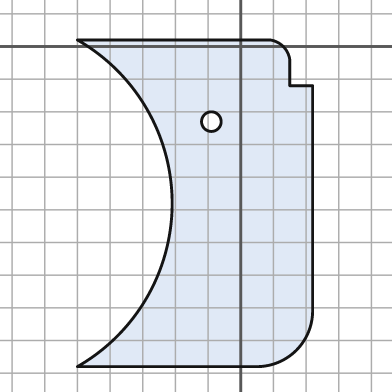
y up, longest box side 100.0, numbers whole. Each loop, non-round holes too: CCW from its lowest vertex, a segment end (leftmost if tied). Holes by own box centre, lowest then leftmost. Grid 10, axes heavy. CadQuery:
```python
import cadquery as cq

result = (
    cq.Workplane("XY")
    .moveTo(-50.0, -98.0)
    .lineTo(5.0, -98.0)
    .threePointArc((17.0, -93.0), (22.0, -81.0))
    .lineTo(22.0, -12.0)
    .lineTo(15.0, -12.0)
    .lineTo(15.0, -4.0)
    .threePointArc((13.0, 0.0), (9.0, 2.0))
    .lineTo(-50.0, 2.0)
    .threePointArc((-21.0, -48.0), (-50.0, -98.0))
    .close()
    .moveTo(-9.0, -23.0)
    .circle(3.0)
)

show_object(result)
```